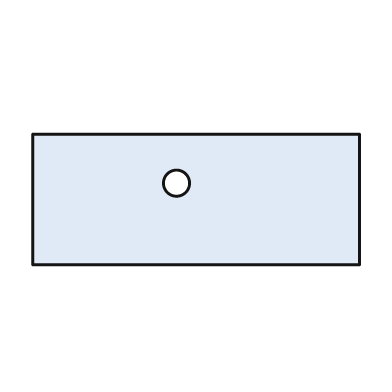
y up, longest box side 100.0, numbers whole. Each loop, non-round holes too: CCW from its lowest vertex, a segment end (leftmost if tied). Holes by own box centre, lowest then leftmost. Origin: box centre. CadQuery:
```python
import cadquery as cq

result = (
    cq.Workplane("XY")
    .moveTo(-50.0, -20.0)
    .lineTo(50.0, -20.0)
    .lineTo(50.0, 20.0)
    .lineTo(-50.0, 20.0)
    .close()
    .moveTo(-6.0, 5.0)
    .circle(4.0)
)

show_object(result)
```